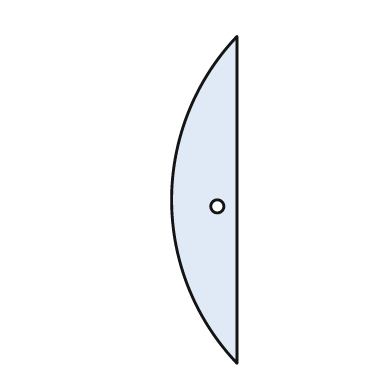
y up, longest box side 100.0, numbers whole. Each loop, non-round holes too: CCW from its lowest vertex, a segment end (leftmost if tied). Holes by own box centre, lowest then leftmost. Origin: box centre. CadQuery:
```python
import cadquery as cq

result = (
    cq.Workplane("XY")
    .moveTo(10.0, -50.0)
    .lineTo(10.0, 50.0)
    .threePointArc((-10.0, 0.0), (10.0, -50.0))
    .close()
    .moveTo(4.0, -2.0)
    .circle(2.0)
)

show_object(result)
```